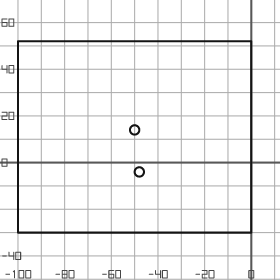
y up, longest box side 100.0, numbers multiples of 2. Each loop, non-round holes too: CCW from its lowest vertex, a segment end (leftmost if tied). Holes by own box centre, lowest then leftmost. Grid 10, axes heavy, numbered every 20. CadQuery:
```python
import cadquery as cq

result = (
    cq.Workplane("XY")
    .moveTo(-100.0, -30.0)
    .lineTo(0.0, -30.0)
    .lineTo(0.0, 52.0)
    .lineTo(-100.0, 52.0)
    .close()
    .moveTo(-48.0, -4.0)
    .circle(2.0)
    .moveTo(-50.0, 14.0)
    .circle(2.0)
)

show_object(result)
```